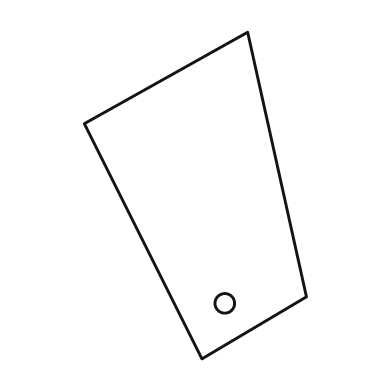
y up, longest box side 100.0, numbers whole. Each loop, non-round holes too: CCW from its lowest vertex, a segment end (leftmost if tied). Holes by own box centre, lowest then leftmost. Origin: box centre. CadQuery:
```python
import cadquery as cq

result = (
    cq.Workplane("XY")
    .moveTo(2.0, -50.0)
    .lineTo(34.0, -31.0)
    .lineTo(16.0, 50.0)
    .lineTo(-34.0, 22.0)
    .close()
    .moveTo(9.0, -33.0)
    .circle(3.0)
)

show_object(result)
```